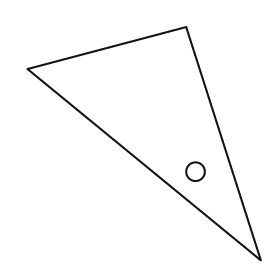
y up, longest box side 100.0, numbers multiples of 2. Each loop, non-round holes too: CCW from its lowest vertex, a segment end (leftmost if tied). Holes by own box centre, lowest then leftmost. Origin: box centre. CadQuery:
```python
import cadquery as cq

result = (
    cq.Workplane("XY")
    .moveTo(50.0, -50.0)
    .lineTo(18.0, 50.0)
    .lineTo(-50.0, 32.0)
    .close()
    .moveTo(22.0, -12.0)
    .circle(4.0)
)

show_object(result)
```